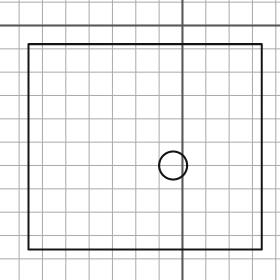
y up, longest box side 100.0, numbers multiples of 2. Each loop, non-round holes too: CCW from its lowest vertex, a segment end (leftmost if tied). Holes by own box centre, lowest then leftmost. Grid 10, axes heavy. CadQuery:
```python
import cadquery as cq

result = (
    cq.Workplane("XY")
    .moveTo(-66.0, -96.0)
    .lineTo(34.0, -96.0)
    .lineTo(34.0, -8.0)
    .lineTo(-66.0, -8.0)
    .close()
    .moveTo(-4.0, -60.0)
    .circle(6.0)
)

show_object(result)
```